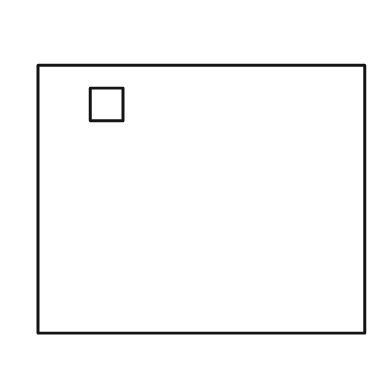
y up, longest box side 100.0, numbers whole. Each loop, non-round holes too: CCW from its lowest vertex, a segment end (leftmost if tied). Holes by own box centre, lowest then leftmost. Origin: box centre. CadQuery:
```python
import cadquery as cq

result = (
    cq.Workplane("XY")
    .moveTo(-50.0, -41.0)
    .lineTo(50.0, -41.0)
    .lineTo(50.0, 41.0)
    .lineTo(-50.0, 41.0)
    .close()
    .moveTo(-34.0, 24.0)
    .lineTo(-24.0, 24.0)
    .lineTo(-24.0, 34.0)
    .lineTo(-34.0, 34.0)
    .close()
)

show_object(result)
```